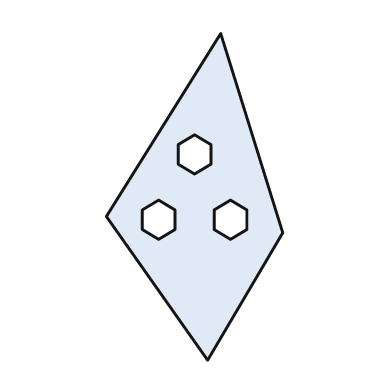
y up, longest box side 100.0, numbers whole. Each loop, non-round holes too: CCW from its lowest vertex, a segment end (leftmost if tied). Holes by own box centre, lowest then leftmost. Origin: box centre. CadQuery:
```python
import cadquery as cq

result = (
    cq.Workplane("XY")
    .moveTo(4.0, -50.0)
    .lineTo(27.0, -11.0)
    .lineTo(8.0, 50.0)
    .lineTo(-27.0, -6.0)
    .close()
    .moveTo(-11.0, -13.0)
    .lineTo(-6.0, -10.0)
    .lineTo(-6.0, -4.0)
    .lineTo(-11.0, -1.0)
    .lineTo(-16.0, -4.0)
    .lineTo(-16.0, -10.0)
    .close()
    .moveTo(11.0, -13.0)
    .lineTo(16.0, -10.0)
    .lineTo(16.0, -4.0)
    .lineTo(11.0, -1.0)
    .lineTo(6.0, -4.0)
    .lineTo(6.0, -10.0)
    .close()
    .moveTo(0.0, 7.0)
    .lineTo(5.0, 10.0)
    .lineTo(5.0, 16.0)
    .lineTo(0.0, 19.0)
    .lineTo(-5.0, 16.0)
    .lineTo(-5.0, 10.0)
    .close()
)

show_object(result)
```